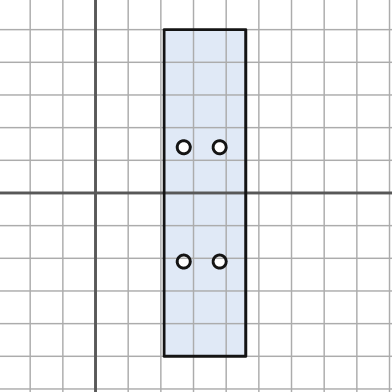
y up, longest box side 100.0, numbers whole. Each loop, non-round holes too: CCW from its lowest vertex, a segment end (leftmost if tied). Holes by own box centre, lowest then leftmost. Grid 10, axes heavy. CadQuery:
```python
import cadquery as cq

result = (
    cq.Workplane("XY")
    .moveTo(21.0, -50.0)
    .lineTo(46.0, -50.0)
    .lineTo(46.0, 50.0)
    .lineTo(21.0, 50.0)
    .close()
    .moveTo(27.0, -21.0)
    .circle(2.0)
    .moveTo(38.0, -21.0)
    .circle(2.0)
    .moveTo(27.0, 14.0)
    .circle(2.0)
    .moveTo(38.0, 14.0)
    .circle(2.0)
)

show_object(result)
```